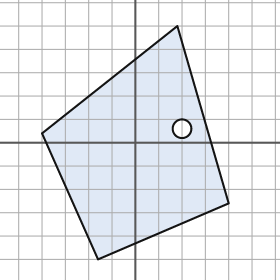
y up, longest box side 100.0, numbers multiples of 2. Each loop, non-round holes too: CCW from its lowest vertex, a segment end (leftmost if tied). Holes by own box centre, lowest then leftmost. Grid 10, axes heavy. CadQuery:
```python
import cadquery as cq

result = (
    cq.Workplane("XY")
    .moveTo(-16.0, -50.0)
    .lineTo(40.0, -26.0)
    .lineTo(18.0, 50.0)
    .lineTo(-40.0, 4.0)
    .close()
    .moveTo(20.0, 6.0)
    .circle(4.0)
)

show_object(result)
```